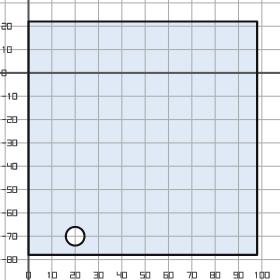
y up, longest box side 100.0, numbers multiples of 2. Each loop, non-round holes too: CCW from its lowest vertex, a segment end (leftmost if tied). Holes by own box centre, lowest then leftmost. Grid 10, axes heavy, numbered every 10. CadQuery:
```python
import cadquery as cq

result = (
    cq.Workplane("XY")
    .moveTo(0.0, -78.0)
    .lineTo(98.0, -78.0)
    .lineTo(98.0, 22.0)
    .lineTo(0.0, 22.0)
    .close()
    .moveTo(20.0, -70.0)
    .circle(4.0)
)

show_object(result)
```